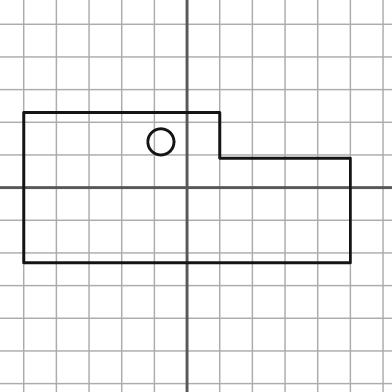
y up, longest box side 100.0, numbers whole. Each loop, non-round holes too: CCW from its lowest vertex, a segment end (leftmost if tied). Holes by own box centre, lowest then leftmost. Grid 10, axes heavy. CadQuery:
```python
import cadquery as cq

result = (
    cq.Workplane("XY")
    .moveTo(-50.0, -23.0)
    .lineTo(50.0, -23.0)
    .lineTo(50.0, 9.0)
    .lineTo(10.0, 9.0)
    .lineTo(10.0, 23.0)
    .lineTo(-50.0, 23.0)
    .close()
    .moveTo(-8.0, 14.0)
    .circle(4.0)
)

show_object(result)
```